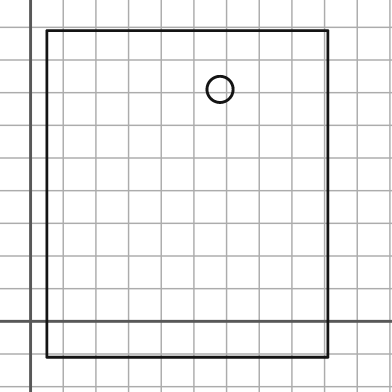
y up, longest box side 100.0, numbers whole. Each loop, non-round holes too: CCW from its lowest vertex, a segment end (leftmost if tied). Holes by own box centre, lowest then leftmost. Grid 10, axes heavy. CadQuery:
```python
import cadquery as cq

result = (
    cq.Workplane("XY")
    .moveTo(5.0, -11.0)
    .lineTo(91.0, -11.0)
    .lineTo(91.0, 89.0)
    .lineTo(5.0, 89.0)
    .close()
    .moveTo(58.0, 71.0)
    .circle(4.0)
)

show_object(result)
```